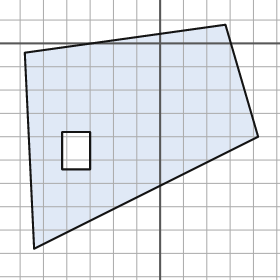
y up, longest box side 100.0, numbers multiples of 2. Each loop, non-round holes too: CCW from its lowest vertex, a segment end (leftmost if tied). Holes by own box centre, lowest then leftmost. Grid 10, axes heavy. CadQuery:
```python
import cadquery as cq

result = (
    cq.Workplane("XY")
    .moveTo(-54.0, -88.0)
    .lineTo(42.0, -40.0)
    .lineTo(28.0, 8.0)
    .lineTo(-58.0, -4.0)
    .close()
    .moveTo(-42.0, -54.0)
    .lineTo(-30.0, -54.0)
    .lineTo(-30.0, -38.0)
    .lineTo(-42.0, -38.0)
    .close()
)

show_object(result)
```